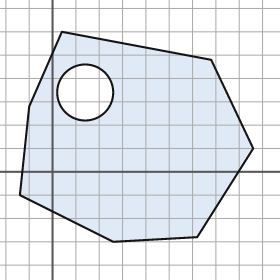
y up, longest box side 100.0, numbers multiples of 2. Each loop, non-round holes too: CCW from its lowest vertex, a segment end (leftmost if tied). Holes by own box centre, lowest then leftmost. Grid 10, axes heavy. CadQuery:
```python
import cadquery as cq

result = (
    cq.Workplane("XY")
    .moveTo(26.0, -30.0)
    .lineTo(62.0, -28.0)
    .lineTo(86.0, 10.0)
    .lineTo(68.0, 48.0)
    .lineTo(4.0, 60.0)
    .lineTo(-10.0, 28.0)
    .lineTo(-14.0, -10.0)
    .close()
    .moveTo(14.0, 34.0)
    .circle(12.0)
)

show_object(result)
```